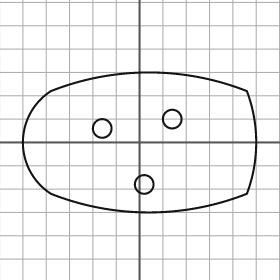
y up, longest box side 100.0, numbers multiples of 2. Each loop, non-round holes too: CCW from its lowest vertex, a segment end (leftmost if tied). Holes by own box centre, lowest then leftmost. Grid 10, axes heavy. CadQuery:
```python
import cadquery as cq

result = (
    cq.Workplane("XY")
    .moveTo(-38.0, -22.0)
    .threePointArc((4.0, -30.0), (46.0, -22.0))
    .threePointArc((50.0, 0.0), (46.0, 22.0))
    .threePointArc((4.0, 30.0), (-38.0, 22.0))
    .threePointArc((-50.0, 0.0), (-38.0, -22.0))
    .close()
    .moveTo(2.0, -18.0)
    .circle(4.0)
    .moveTo(-16.0, 6.0)
    .circle(4.0)
    .moveTo(14.0, 10.0)
    .circle(4.0)
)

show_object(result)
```